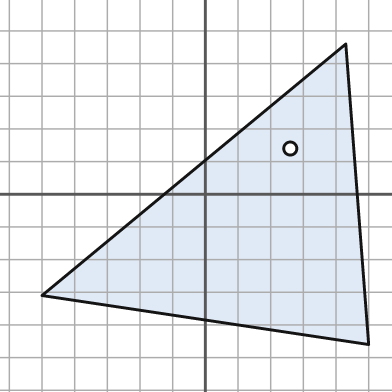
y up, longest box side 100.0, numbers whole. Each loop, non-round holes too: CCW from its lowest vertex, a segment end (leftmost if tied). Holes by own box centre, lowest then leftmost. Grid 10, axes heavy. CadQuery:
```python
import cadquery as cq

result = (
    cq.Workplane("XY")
    .moveTo(50.0, -46.0)
    .lineTo(43.0, 46.0)
    .lineTo(-50.0, -31.0)
    .close()
    .moveTo(26.0, 14.0)
    .circle(2.0)
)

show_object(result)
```